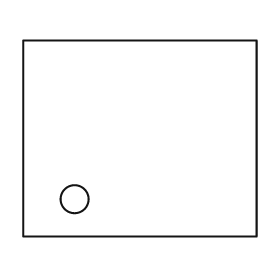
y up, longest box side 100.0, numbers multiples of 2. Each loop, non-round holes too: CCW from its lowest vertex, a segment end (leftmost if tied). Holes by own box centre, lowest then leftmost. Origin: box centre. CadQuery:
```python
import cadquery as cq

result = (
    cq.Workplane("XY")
    .moveTo(-50.0, -42.0)
    .lineTo(50.0, -42.0)
    .lineTo(50.0, 42.0)
    .lineTo(-50.0, 42.0)
    .close()
    .moveTo(-28.0, -26.0)
    .circle(6.0)
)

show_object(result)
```